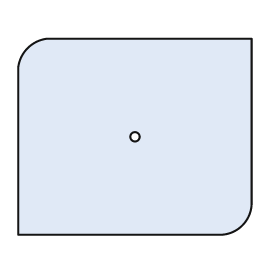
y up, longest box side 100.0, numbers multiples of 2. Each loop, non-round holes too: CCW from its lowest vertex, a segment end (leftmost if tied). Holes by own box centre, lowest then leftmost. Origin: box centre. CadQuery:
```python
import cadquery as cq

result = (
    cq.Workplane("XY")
    .moveTo(-50.0, -42.0)
    .lineTo(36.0, -42.0)
    .threePointArc((46.0, -38.0), (50.0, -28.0))
    .lineTo(50.0, 42.0)
    .lineTo(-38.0, 42.0)
    .threePointArc((-46.0, 38.0), (-50.0, 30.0))
    .close()
    .moveTo(0.0, 0.0)
    .circle(2.0)
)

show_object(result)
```